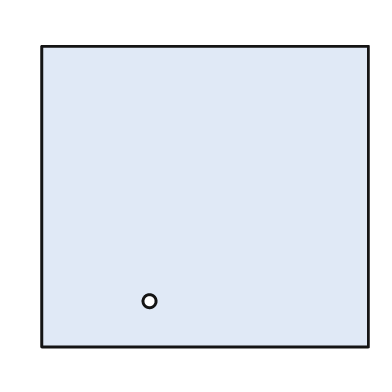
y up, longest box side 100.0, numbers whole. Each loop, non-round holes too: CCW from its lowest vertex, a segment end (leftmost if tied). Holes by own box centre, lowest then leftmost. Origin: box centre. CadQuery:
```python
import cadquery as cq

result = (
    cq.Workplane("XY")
    .moveTo(-50.0, -46.0)
    .lineTo(50.0, -46.0)
    .lineTo(50.0, 46.0)
    .lineTo(-50.0, 46.0)
    .close()
    .moveTo(-17.0, -32.0)
    .circle(2.0)
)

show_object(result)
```